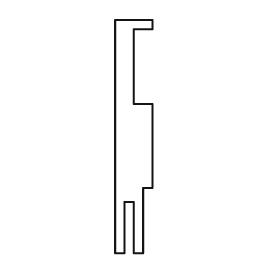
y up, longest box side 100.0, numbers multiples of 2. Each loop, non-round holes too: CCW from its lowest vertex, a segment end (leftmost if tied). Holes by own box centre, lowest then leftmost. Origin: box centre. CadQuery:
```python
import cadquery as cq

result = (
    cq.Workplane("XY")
    .moveTo(-8.0, -50.0)
    .lineTo(-4.0, -50.0)
    .lineTo(-4.0, -28.0)
    .lineTo(0.0, -28.0)
    .lineTo(0.0, -50.0)
    .lineTo(4.0, -50.0)
    .lineTo(4.0, -22.0)
    .lineTo(8.0, -22.0)
    .lineTo(8.0, 14.0)
    .lineTo(0.0, 14.0)
    .lineTo(0.0, 46.0)
    .lineTo(8.0, 46.0)
    .lineTo(8.0, 50.0)
    .lineTo(-8.0, 50.0)
    .close()
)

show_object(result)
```